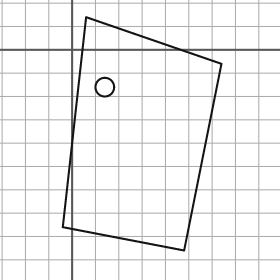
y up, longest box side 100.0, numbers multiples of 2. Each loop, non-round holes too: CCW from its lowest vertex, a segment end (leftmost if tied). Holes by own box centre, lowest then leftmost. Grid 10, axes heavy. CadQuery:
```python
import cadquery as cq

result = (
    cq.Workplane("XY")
    .moveTo(48.0, -86.0)
    .lineTo(64.0, -6.0)
    .lineTo(6.0, 14.0)
    .lineTo(-4.0, -76.0)
    .close()
    .moveTo(14.0, -16.0)
    .circle(4.0)
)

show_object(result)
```